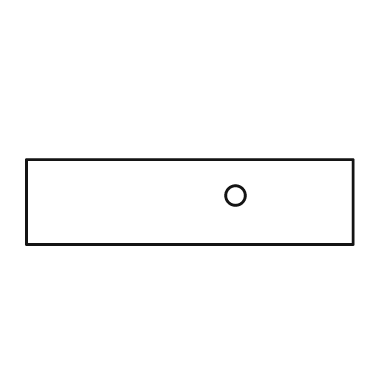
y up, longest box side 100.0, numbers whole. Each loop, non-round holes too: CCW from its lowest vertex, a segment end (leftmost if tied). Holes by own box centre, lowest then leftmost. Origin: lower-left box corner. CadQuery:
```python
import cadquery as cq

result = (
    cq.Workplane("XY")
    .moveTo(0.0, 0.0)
    .lineTo(100.0, 0.0)
    .lineTo(100.0, 26.0)
    .lineTo(0.0, 26.0)
    .close()
    .moveTo(64.0, 15.0)
    .circle(3.0)
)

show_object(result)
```